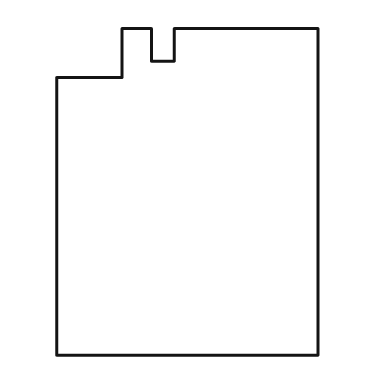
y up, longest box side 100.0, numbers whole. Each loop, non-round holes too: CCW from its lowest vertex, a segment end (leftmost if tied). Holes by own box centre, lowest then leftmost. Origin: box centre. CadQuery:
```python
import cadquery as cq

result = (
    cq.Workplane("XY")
    .moveTo(-40.0, -50.0)
    .lineTo(40.0, -50.0)
    .lineTo(40.0, 50.0)
    .lineTo(-4.0, 50.0)
    .lineTo(-4.0, 40.0)
    .lineTo(-11.0, 40.0)
    .lineTo(-11.0, 50.0)
    .lineTo(-20.0, 50.0)
    .lineTo(-20.0, 35.0)
    .lineTo(-40.0, 35.0)
    .close()
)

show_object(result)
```